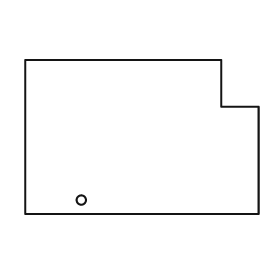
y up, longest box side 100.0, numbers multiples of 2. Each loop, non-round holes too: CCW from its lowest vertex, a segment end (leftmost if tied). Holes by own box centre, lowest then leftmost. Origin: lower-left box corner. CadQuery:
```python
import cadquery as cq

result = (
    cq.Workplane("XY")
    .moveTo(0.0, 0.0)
    .lineTo(100.0, 0.0)
    .lineTo(100.0, 46.0)
    .lineTo(84.0, 46.0)
    .lineTo(84.0, 66.0)
    .lineTo(0.0, 66.0)
    .close()
    .moveTo(24.0, 6.0)
    .circle(2.0)
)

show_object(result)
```